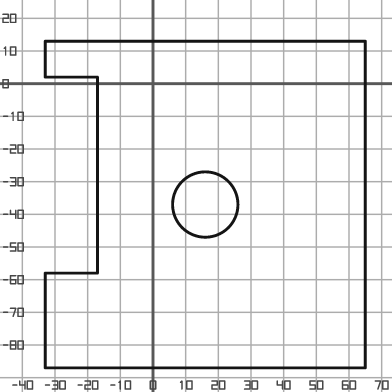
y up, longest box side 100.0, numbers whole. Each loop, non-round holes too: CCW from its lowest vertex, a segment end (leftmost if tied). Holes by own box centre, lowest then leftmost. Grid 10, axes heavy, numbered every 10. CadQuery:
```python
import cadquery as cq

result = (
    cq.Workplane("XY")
    .moveTo(-33.0, -87.0)
    .lineTo(65.0, -87.0)
    .lineTo(65.0, 13.0)
    .lineTo(-33.0, 13.0)
    .lineTo(-33.0, 2.0)
    .lineTo(-17.0, 2.0)
    .lineTo(-17.0, -58.0)
    .lineTo(-33.0, -58.0)
    .close()
    .moveTo(16.0, -37.0)
    .circle(10.0)
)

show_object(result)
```